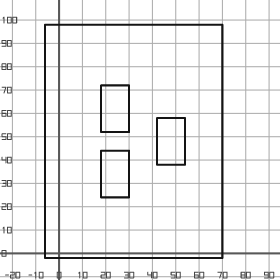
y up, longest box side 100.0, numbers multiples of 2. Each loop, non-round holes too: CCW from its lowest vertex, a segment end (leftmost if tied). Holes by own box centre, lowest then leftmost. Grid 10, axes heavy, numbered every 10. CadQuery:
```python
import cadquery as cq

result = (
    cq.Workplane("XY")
    .moveTo(-6.0, -2.0)
    .lineTo(70.0, -2.0)
    .lineTo(70.0, 98.0)
    .lineTo(-6.0, 98.0)
    .close()
    .moveTo(18.0, 24.0)
    .lineTo(30.0, 24.0)
    .lineTo(30.0, 44.0)
    .lineTo(18.0, 44.0)
    .close()
    .moveTo(42.0, 38.0)
    .lineTo(54.0, 38.0)
    .lineTo(54.0, 58.0)
    .lineTo(42.0, 58.0)
    .close()
    .moveTo(18.0, 52.0)
    .lineTo(30.0, 52.0)
    .lineTo(30.0, 72.0)
    .lineTo(18.0, 72.0)
    .close()
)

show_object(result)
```